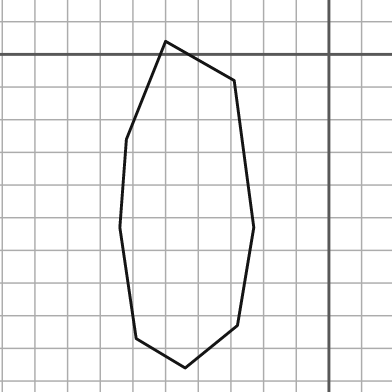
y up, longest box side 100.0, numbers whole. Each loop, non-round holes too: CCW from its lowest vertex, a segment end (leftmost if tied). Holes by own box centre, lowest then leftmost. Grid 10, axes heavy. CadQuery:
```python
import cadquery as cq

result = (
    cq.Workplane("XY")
    .moveTo(-44.0, -96.0)
    .lineTo(-28.0, -83.0)
    .lineTo(-23.0, -53.0)
    .lineTo(-29.0, -8.0)
    .lineTo(-50.0, 4.0)
    .lineTo(-62.0, -26.0)
    .lineTo(-64.0, -53.0)
    .lineTo(-59.0, -87.0)
    .close()
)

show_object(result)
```